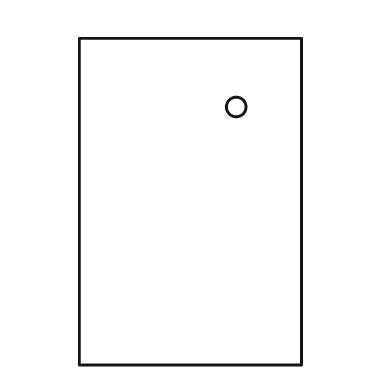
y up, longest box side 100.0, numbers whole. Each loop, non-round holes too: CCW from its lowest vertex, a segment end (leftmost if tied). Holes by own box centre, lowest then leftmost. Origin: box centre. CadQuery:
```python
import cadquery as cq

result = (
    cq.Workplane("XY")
    .moveTo(-34.0, -50.0)
    .lineTo(34.0, -50.0)
    .lineTo(34.0, 50.0)
    .lineTo(-34.0, 50.0)
    .close()
    .moveTo(14.0, 29.0)
    .circle(3.0)
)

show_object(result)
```